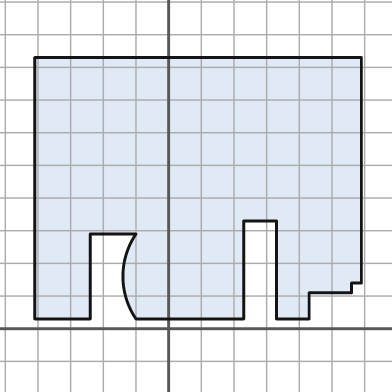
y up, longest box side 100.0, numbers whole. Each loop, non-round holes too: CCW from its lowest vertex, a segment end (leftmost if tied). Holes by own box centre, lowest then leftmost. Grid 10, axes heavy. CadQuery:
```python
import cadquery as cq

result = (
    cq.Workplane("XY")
    .moveTo(-41.0, 3.0)
    .lineTo(-24.0, 3.0)
    .lineTo(-24.0, 29.0)
    .lineTo(-10.0, 29.0)
    .threePointArc((-14.0, 16.0), (-10.0, 3.0))
    .lineTo(23.0, 3.0)
    .lineTo(23.0, 33.0)
    .lineTo(33.0, 33.0)
    .lineTo(33.0, 3.0)
    .lineTo(43.0, 3.0)
    .lineTo(43.0, 11.0)
    .lineTo(56.0, 11.0)
    .lineTo(56.0, 14.0)
    .lineTo(59.0, 14.0)
    .lineTo(59.0, 83.0)
    .lineTo(-41.0, 83.0)
    .close()
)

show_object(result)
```